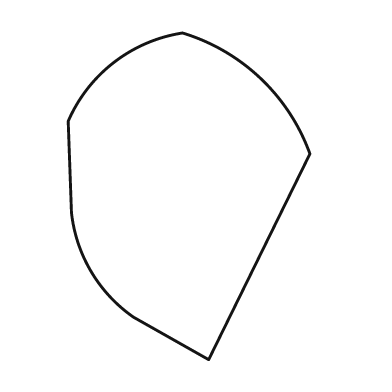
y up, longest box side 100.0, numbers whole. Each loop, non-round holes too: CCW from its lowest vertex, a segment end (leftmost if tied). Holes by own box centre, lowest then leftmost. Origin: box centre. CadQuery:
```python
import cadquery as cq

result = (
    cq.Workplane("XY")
    .moveTo(6.0, -50.0)
    .lineTo(37.0, 13.0)
    .threePointArc((22.0, 36.0), (-2.0, 50.0))
    .threePointArc((-23.0, 41.0), (-37.0, 23.0))
    .lineTo(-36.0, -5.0)
    .threePointArc((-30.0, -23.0), (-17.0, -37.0))
    .close()
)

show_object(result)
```